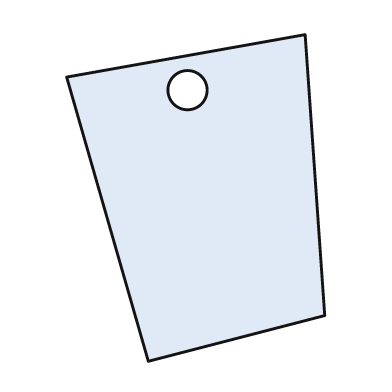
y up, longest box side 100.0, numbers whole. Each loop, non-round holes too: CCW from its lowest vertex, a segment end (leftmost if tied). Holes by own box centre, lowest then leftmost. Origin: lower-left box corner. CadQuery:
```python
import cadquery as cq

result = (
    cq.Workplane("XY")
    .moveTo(25.0, 0.0)
    .lineTo(79.0, 14.0)
    .lineTo(73.0, 100.0)
    .lineTo(0.0, 87.0)
    .close()
    .moveTo(37.0, 83.0)
    .circle(6.0)
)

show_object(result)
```